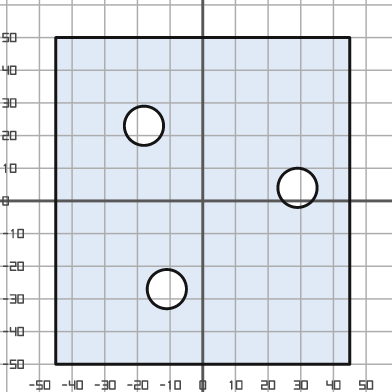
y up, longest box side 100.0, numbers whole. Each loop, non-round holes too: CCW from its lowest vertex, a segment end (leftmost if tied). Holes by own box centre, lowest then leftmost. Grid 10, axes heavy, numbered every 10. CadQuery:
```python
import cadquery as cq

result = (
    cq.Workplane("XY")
    .moveTo(-45.0, -50.0)
    .lineTo(45.0, -50.0)
    .lineTo(45.0, 50.0)
    .lineTo(-45.0, 50.0)
    .close()
    .moveTo(-11.0, -27.0)
    .circle(6.0)
    .moveTo(29.0, 4.0)
    .circle(6.0)
    .moveTo(-18.0, 23.0)
    .circle(6.0)
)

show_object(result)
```